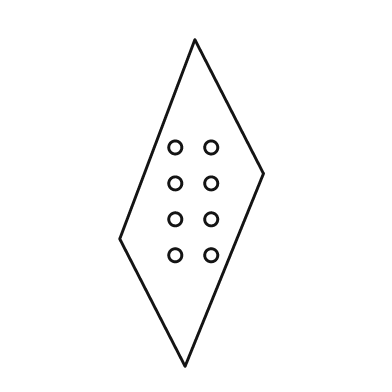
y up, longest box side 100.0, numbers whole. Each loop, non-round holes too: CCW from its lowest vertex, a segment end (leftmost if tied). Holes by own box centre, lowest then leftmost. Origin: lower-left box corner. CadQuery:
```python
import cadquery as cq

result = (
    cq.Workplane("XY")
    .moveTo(20.0, 0.0)
    .lineTo(44.0, 59.0)
    .lineTo(23.0, 100.0)
    .lineTo(0.0, 39.0)
    .close()
    .moveTo(17.0, 34.0)
    .circle(2.0)
    .moveTo(28.0, 34.0)
    .circle(2.0)
    .moveTo(17.0, 45.0)
    .circle(2.0)
    .moveTo(28.0, 45.0)
    .circle(2.0)
    .moveTo(17.0, 56.0)
    .circle(2.0)
    .moveTo(28.0, 56.0)
    .circle(2.0)
    .moveTo(17.0, 67.0)
    .circle(2.0)
    .moveTo(28.0, 67.0)
    .circle(2.0)
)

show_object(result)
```